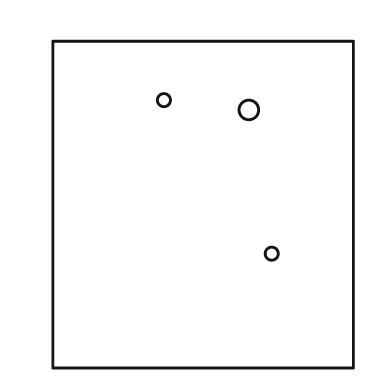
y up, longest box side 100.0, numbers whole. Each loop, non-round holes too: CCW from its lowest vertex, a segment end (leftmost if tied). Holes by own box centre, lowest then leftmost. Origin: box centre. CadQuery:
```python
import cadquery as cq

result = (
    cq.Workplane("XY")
    .moveTo(-46.0, -50.0)
    .lineTo(46.0, -50.0)
    .lineTo(46.0, 50.0)
    .lineTo(-46.0, 50.0)
    .close()
    .moveTo(21.0, -15.0)
    .circle(2.0)
    .moveTo(14.0, 29.0)
    .circle(3.0)
    .moveTo(-12.0, 32.0)
    .circle(2.0)
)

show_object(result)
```